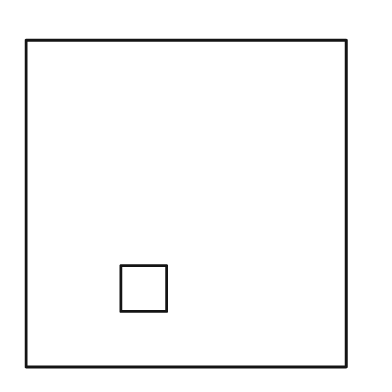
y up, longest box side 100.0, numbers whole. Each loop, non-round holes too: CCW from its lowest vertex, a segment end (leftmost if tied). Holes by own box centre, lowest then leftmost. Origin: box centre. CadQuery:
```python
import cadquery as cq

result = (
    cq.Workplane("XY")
    .moveTo(-49.0, -50.0)
    .lineTo(49.0, -50.0)
    .lineTo(49.0, 50.0)
    .lineTo(-49.0, 50.0)
    .close()
    .moveTo(-20.0, -33.0)
    .lineTo(-6.0, -33.0)
    .lineTo(-6.0, -19.0)
    .lineTo(-20.0, -19.0)
    .close()
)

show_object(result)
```